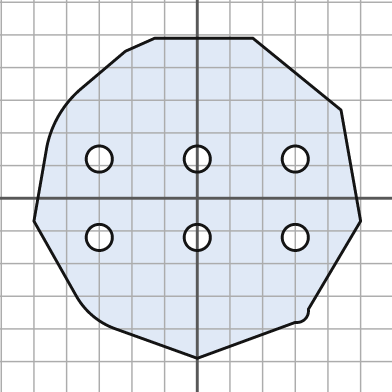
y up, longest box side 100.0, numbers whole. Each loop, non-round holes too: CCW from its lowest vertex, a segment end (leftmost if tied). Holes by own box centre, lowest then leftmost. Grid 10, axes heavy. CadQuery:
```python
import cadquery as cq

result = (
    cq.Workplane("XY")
    .moveTo(0.0, -49.0)
    .lineTo(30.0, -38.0)
    .threePointArc((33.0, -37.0), (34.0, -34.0))
    .lineTo(50.0, -7.0)
    .lineTo(44.0, 27.0)
    .lineTo(17.0, 49.0)
    .lineTo(-13.0, 49.0)
    .lineTo(-22.0, 45.0)
    .lineTo(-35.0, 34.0)
    .threePointArc((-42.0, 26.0), (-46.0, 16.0))
    .lineTo(-50.0, -7.0)
    .lineTo(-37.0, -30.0)
    .threePointArc((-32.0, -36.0), (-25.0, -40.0))
    .close()
    .moveTo(-30.0, -12.0)
    .circle(4.0)
    .moveTo(0.0, -12.0)
    .circle(4.0)
    .moveTo(30.0, -12.0)
    .circle(4.0)
    .moveTo(-30.0, 12.0)
    .circle(4.0)
    .moveTo(0.0, 12.0)
    .circle(4.0)
    .moveTo(30.0, 12.0)
    .circle(4.0)
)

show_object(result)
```